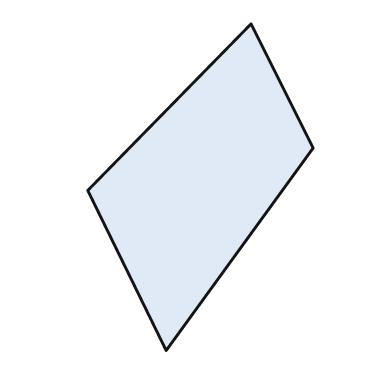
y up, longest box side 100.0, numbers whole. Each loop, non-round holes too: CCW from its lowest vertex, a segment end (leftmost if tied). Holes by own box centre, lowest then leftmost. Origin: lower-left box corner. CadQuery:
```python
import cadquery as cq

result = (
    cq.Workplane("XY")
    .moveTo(24.0, 0.0)
    .lineTo(69.0, 62.0)
    .lineTo(50.0, 100.0)
    .lineTo(0.0, 49.0)
    .close()
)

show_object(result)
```